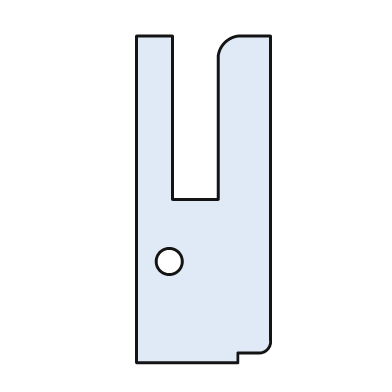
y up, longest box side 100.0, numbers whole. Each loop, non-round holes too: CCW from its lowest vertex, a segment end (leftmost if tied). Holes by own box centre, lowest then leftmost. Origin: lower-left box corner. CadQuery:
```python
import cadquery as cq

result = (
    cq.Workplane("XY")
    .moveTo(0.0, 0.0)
    .lineTo(31.0, 0.0)
    .lineTo(31.0, 3.0)
    .lineTo(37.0, 3.0)
    .threePointArc((40.0, 4.0), (41.0, 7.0))
    .lineTo(41.0, 100.0)
    .lineTo(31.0, 100.0)
    .threePointArc((27.0, 98.0), (25.0, 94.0))
    .lineTo(25.0, 50.0)
    .lineTo(11.0, 50.0)
    .lineTo(11.0, 100.0)
    .lineTo(0.0, 100.0)
    .close()
    .moveTo(10.0, 31.0)
    .circle(4.0)
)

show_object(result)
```